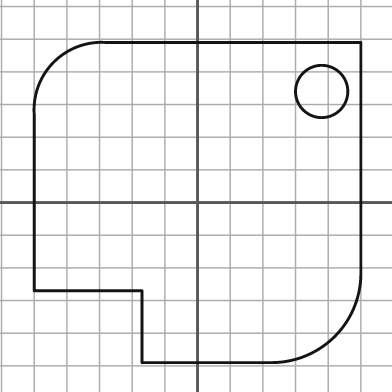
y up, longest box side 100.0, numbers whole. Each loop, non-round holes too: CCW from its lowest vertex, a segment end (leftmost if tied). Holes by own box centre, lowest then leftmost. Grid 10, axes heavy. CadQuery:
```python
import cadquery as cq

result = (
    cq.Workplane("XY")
    .moveTo(-17.0, -49.0)
    .lineTo(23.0, -49.0)
    .threePointArc((42.0, -41.0), (50.0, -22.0))
    .lineTo(50.0, 49.0)
    .lineTo(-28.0, 49.0)
    .threePointArc((-44.0, 43.0), (-50.0, 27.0))
    .lineTo(-50.0, -27.0)
    .lineTo(-17.0, -27.0)
    .close()
    .moveTo(38.0, 34.0)
    .circle(8.0)
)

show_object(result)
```